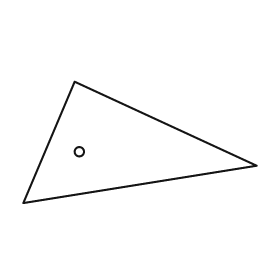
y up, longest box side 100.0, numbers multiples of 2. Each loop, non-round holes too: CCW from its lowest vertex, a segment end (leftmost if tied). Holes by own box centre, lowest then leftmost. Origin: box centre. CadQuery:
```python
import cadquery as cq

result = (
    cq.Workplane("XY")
    .moveTo(-50.0, -26.0)
    .lineTo(50.0, -10.0)
    .lineTo(-28.0, 26.0)
    .close()
    .moveTo(-26.0, -4.0)
    .circle(2.0)
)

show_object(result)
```